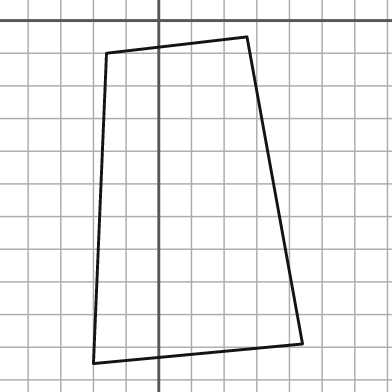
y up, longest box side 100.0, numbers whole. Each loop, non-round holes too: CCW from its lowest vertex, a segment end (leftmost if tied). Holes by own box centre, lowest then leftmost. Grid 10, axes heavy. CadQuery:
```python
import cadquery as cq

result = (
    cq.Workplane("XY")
    .moveTo(-20.0, -105.0)
    .lineTo(44.0, -99.0)
    .lineTo(27.0, -5.0)
    .lineTo(-16.0, -10.0)
    .close()
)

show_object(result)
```